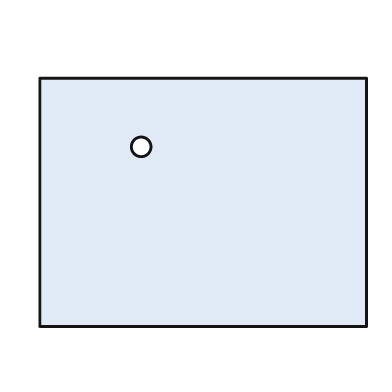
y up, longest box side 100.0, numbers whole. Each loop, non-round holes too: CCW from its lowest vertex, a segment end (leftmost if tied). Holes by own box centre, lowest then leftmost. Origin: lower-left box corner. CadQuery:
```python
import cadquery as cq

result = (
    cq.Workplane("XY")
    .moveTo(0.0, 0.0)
    .lineTo(100.0, 0.0)
    .lineTo(100.0, 76.0)
    .lineTo(0.0, 76.0)
    .close()
    .moveTo(31.0, 55.0)
    .circle(3.0)
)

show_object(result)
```